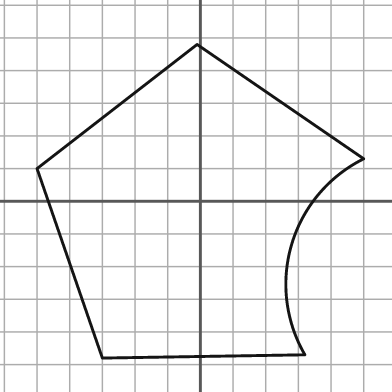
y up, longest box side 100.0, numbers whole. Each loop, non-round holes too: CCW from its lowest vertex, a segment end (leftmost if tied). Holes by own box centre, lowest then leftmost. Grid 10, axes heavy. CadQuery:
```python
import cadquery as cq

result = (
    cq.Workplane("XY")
    .moveTo(-30.0, -48.0)
    .lineTo(32.0, -47.0)
    .threePointArc((28.0, -13.0), (50.0, 13.0))
    .lineTo(-1.0, 48.0)
    .lineTo(-50.0, 10.0)
    .close()
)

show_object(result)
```